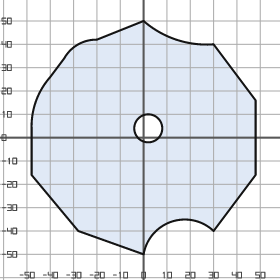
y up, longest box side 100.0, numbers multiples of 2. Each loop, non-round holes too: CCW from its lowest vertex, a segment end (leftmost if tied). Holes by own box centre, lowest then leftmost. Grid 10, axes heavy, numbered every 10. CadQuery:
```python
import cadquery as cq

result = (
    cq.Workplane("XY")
    .moveTo(0.0, -50.0)
    .threePointArc((12.0, -36.0), (30.0, -40.0))
    .lineTo(48.0, -16.0)
    .lineTo(48.0, 16.0)
    .lineTo(30.0, 40.0)
    .threePointArc((14.0, 42.0), (0.0, 50.0))
    .lineTo(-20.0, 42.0)
    .threePointArc((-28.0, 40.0), (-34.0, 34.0))
    .lineTo(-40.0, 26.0)
    .threePointArc((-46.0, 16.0), (-48.0, 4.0))
    .lineTo(-48.0, -16.0)
    .lineTo(-28.0, -40.0)
    .close()
    .moveTo(2.0, 4.0)
    .circle(6.0)
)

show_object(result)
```